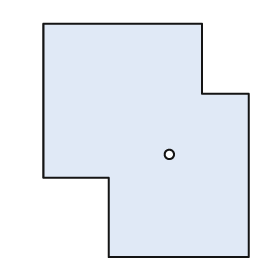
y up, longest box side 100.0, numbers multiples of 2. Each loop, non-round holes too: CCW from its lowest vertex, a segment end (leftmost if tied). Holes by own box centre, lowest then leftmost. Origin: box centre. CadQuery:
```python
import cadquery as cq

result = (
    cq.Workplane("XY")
    .moveTo(-16.0, -50.0)
    .lineTo(44.0, -50.0)
    .lineTo(44.0, 20.0)
    .lineTo(24.0, 20.0)
    .lineTo(24.0, 50.0)
    .lineTo(-44.0, 50.0)
    .lineTo(-44.0, -16.0)
    .lineTo(-16.0, -16.0)
    .close()
    .moveTo(10.0, -6.0)
    .circle(2.0)
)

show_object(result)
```